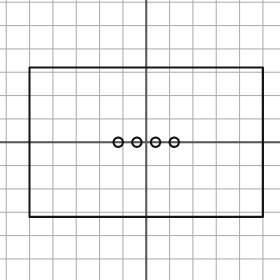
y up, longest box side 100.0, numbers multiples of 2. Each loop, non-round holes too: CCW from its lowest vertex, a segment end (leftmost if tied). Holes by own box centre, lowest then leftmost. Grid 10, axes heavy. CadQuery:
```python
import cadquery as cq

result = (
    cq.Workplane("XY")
    .moveTo(-50.0, -32.0)
    .lineTo(50.0, -32.0)
    .lineTo(50.0, 32.0)
    .lineTo(-50.0, 32.0)
    .close()
    .moveTo(-12.0, 0.0)
    .circle(2.0)
    .moveTo(-4.0, 0.0)
    .circle(2.0)
    .moveTo(4.0, 0.0)
    .circle(2.0)
    .moveTo(12.0, 0.0)
    .circle(2.0)
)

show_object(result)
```